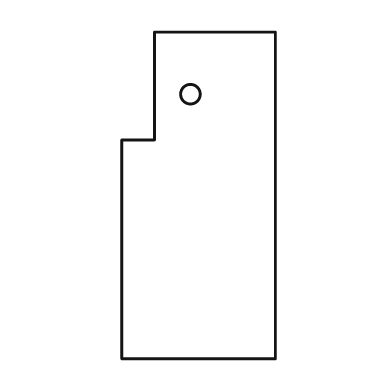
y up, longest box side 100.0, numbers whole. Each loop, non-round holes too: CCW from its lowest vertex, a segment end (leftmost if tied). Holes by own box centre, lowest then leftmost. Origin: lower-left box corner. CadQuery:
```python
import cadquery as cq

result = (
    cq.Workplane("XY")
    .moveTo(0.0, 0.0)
    .lineTo(47.0, 0.0)
    .lineTo(47.0, 100.0)
    .lineTo(10.0, 100.0)
    .lineTo(10.0, 67.0)
    .lineTo(0.0, 67.0)
    .close()
    .moveTo(21.0, 81.0)
    .circle(3.0)
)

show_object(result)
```